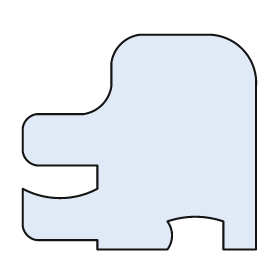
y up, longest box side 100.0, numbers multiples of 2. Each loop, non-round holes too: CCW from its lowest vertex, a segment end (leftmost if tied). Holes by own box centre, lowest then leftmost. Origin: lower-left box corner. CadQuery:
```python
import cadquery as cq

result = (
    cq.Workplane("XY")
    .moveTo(32.0, 0.0)
    .lineTo(62.0, 0.0)
    .threePointArc((64.0, 6.0), (62.0, 12.0))
    .threePointArc((74.0, 14.0), (86.0, 12.0))
    .lineTo(86.0, 0.0)
    .lineTo(100.0, 0.0)
    .lineTo(100.0, 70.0)
    .threePointArc((94.0, 86.0), (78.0, 92.0))
    .lineTo(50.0, 92.0)
    .threePointArc((42.0, 88.0), (38.0, 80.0))
    .lineTo(38.0, 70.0)
    .threePointArc((34.0, 62.0), (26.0, 58.0))
    .lineTo(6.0, 58.0)
    .threePointArc((2.0, 56.0), (0.0, 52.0))
    .lineTo(0.0, 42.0)
    .threePointArc((2.0, 38.0), (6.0, 36.0))
    .lineTo(32.0, 36.0)
    .lineTo(32.0, 26.0)
    .threePointArc((16.0, 22.0), (0.0, 26.0))
    .lineTo(0.0, 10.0)
    .threePointArc((2.0, 6.0), (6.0, 4.0))
    .lineTo(32.0, 4.0)
    .close()
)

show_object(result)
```